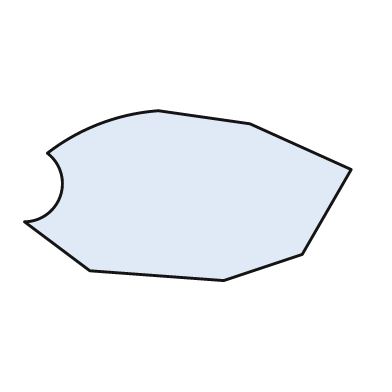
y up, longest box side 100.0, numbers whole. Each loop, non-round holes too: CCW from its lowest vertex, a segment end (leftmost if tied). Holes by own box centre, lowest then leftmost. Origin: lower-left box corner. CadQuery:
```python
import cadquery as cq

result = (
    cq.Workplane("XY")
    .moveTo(61.0, 0.0)
    .lineTo(85.0, 8.0)
    .lineTo(100.0, 34.0)
    .lineTo(69.0, 48.0)
    .lineTo(41.0, 52.0)
    .threePointArc((23.0, 48.0), (7.0, 39.0))
    .threePointArc((11.0, 26.0), (0.0, 18.0))
    .lineTo(20.0, 3.0)
    .close()
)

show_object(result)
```